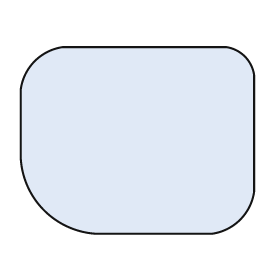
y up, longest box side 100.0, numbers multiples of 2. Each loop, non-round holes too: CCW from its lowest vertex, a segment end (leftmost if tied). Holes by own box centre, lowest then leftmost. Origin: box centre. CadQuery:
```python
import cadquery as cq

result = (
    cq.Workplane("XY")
    .moveTo(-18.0, -40.0)
    .lineTo(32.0, -40.0)
    .threePointArc((44.0, -34.0), (50.0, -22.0))
    .lineTo(50.0, 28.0)
    .threePointArc((46.0, 36.0), (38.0, 40.0))
    .lineTo(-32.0, 40.0)
    .threePointArc((-44.0, 34.0), (-50.0, 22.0))
    .lineTo(-50.0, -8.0)
    .threePointArc((-40.0, -30.0), (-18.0, -40.0))
    .close()
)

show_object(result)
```